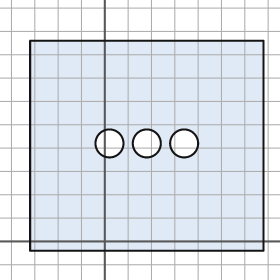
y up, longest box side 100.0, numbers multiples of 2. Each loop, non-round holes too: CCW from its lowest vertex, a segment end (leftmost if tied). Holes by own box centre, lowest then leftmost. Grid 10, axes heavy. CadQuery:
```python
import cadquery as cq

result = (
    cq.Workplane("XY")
    .moveTo(-32.0, -4.0)
    .lineTo(68.0, -4.0)
    .lineTo(68.0, 86.0)
    .lineTo(-32.0, 86.0)
    .close()
    .moveTo(2.0, 42.0)
    .circle(6.0)
    .moveTo(18.0, 42.0)
    .circle(6.0)
    .moveTo(34.0, 42.0)
    .circle(6.0)
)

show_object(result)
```